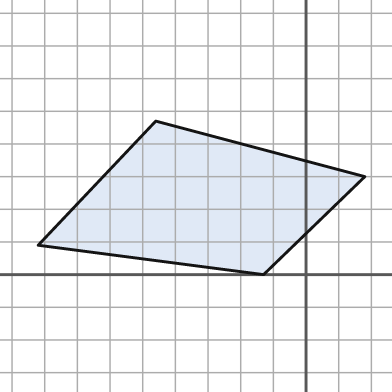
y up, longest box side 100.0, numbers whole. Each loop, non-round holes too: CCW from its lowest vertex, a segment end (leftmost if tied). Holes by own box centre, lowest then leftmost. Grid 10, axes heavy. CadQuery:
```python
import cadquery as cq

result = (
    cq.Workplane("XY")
    .moveTo(-13.0, 0.0)
    .lineTo(18.0, 30.0)
    .lineTo(-46.0, 47.0)
    .lineTo(-82.0, 9.0)
    .close()
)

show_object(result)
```